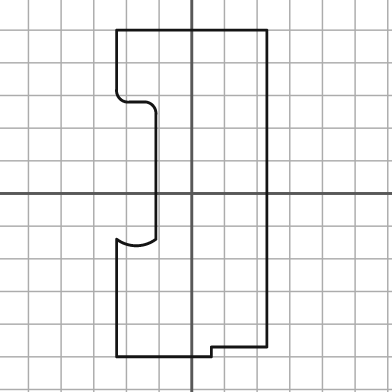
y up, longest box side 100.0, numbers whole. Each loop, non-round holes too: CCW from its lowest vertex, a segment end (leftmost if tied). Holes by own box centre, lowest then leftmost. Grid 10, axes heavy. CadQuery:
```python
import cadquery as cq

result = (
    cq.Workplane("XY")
    .moveTo(-23.0, -50.0)
    .lineTo(6.0, -50.0)
    .lineTo(6.0, -47.0)
    .lineTo(23.0, -47.0)
    .lineTo(23.0, 50.0)
    .lineTo(-23.0, 50.0)
    .lineTo(-23.0, 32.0)
    .threePointArc((-22.0, 29.0), (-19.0, 28.0))
    .lineTo(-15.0, 28.0)
    .threePointArc((-12.0, 27.0), (-11.0, 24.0))
    .lineTo(-11.0, -14.0)
    .threePointArc((-17.0, -16.0), (-23.0, -14.0))
    .close()
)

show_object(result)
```